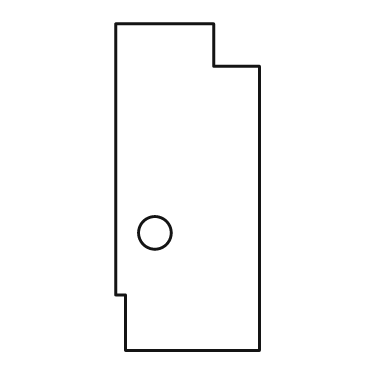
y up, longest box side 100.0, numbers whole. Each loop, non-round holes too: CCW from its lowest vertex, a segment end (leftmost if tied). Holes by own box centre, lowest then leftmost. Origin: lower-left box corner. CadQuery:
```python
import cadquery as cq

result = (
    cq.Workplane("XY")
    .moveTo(3.0, 0.0)
    .lineTo(44.0, 0.0)
    .lineTo(44.0, 87.0)
    .lineTo(30.0, 87.0)
    .lineTo(30.0, 100.0)
    .lineTo(0.0, 100.0)
    .lineTo(0.0, 17.0)
    .lineTo(3.0, 17.0)
    .close()
    .moveTo(12.0, 36.0)
    .circle(5.0)
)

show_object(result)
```